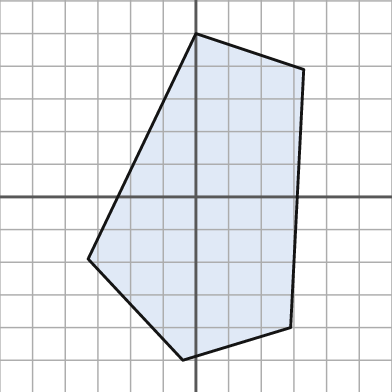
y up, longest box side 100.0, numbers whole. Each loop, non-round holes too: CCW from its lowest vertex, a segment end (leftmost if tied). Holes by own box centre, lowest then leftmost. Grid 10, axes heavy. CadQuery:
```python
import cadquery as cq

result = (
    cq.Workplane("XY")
    .moveTo(-4.0, -50.0)
    .lineTo(29.0, -40.0)
    .lineTo(33.0, 39.0)
    .lineTo(0.0, 50.0)
    .lineTo(-33.0, -19.0)
    .close()
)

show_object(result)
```